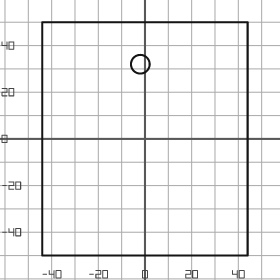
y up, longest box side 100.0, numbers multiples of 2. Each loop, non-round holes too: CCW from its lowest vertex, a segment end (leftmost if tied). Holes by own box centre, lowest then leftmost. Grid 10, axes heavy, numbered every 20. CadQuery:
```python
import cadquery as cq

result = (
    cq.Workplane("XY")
    .moveTo(-44.0, -50.0)
    .lineTo(44.0, -50.0)
    .lineTo(44.0, 50.0)
    .lineTo(-44.0, 50.0)
    .close()
    .moveTo(-2.0, 32.0)
    .circle(4.0)
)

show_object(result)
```